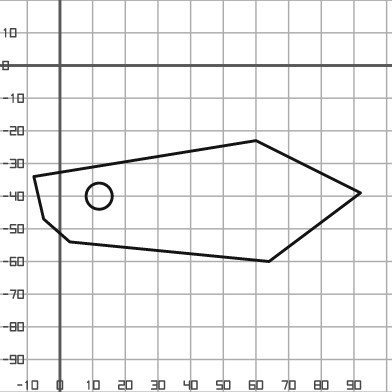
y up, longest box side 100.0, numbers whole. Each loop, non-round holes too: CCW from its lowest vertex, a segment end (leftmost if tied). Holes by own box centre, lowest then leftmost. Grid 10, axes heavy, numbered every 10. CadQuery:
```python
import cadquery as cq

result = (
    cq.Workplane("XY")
    .moveTo(64.0, -60.0)
    .lineTo(92.0, -39.0)
    .lineTo(60.0, -23.0)
    .lineTo(-8.0, -34.0)
    .lineTo(-5.0, -47.0)
    .lineTo(3.0, -54.0)
    .close()
    .moveTo(12.0, -40.0)
    .circle(4.0)
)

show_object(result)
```